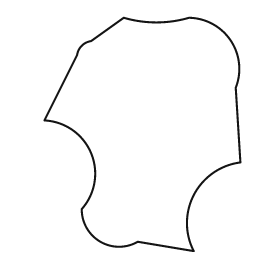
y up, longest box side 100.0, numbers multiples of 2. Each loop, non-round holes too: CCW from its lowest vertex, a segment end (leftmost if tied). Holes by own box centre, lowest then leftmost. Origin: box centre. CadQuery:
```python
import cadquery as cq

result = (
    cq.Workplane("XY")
    .moveTo(22.0, -50.0)
    .threePointArc((22.0, -26.0), (42.0, -12.0))
    .lineTo(40.0, 20.0)
    .threePointArc((38.0, 40.0), (20.0, 50.0))
    .threePointArc((6.0, 48.0), (-8.0, 50.0))
    .lineTo(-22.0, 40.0)
    .threePointArc((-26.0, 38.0), (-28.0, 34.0))
    .lineTo(-42.0, 6.0)
    .threePointArc((-22.0, -8.0), (-26.0, -32.0))
    .threePointArc((-18.0, -46.0), (-2.0, -46.0))
    .close()
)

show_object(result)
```